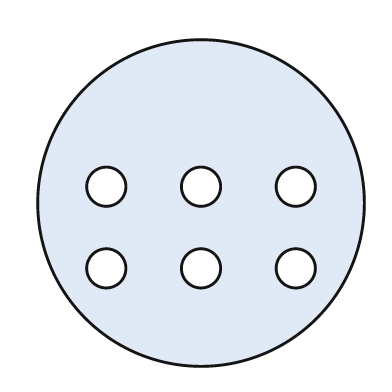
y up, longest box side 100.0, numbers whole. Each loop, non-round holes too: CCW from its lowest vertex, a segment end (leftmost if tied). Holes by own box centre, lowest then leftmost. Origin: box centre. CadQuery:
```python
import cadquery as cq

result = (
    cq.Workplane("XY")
    .moveTo(0.0, 0.0)
    .circle(50.0)
    .moveTo(-29.0, -20.0)
    .circle(6.0)
    .moveTo(0.0, -20.0)
    .circle(6.0)
    .moveTo(29.0, -20.0)
    .circle(6.0)
    .moveTo(-29.0, 5.0)
    .circle(6.0)
    .moveTo(0.0, 5.0)
    .circle(6.0)
    .moveTo(29.0, 5.0)
    .circle(6.0)
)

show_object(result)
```